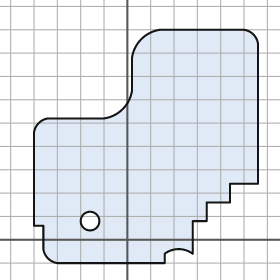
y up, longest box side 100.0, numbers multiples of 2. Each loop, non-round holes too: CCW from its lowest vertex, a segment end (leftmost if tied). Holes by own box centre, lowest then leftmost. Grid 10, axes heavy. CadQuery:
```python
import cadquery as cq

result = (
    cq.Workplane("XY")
    .moveTo(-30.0, -10.0)
    .lineTo(16.0, -10.0)
    .lineTo(16.0, -6.0)
    .threePointArc((22.0, -4.0), (28.0, -6.0))
    .lineTo(28.0, 8.0)
    .lineTo(34.0, 8.0)
    .lineTo(34.0, 16.0)
    .lineTo(44.0, 16.0)
    .lineTo(44.0, 24.0)
    .lineTo(56.0, 24.0)
    .lineTo(56.0, 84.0)
    .threePointArc((54.0, 88.0), (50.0, 90.0))
    .lineTo(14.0, 90.0)
    .threePointArc((6.0, 86.0), (2.0, 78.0))
    .lineTo(2.0, 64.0)
    .threePointArc((-2.0, 56.0), (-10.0, 52.0))
    .lineTo(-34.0, 52.0)
    .threePointArc((-38.0, 50.0), (-40.0, 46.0))
    .lineTo(-40.0, 6.0)
    .lineTo(-36.0, 6.0)
    .lineTo(-36.0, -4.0)
    .threePointArc((-34.0, -8.0), (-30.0, -10.0))
    .close()
    .moveTo(-16.0, 8.0)
    .circle(4.0)
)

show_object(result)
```